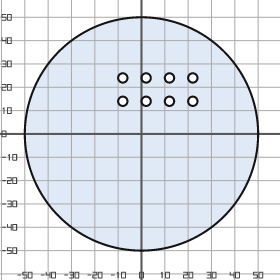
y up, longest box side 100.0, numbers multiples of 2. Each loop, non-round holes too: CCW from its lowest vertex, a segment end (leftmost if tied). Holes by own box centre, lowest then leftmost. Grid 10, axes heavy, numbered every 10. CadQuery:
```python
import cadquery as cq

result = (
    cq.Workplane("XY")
    .moveTo(0.0, 0.0)
    .circle(50.0)
    .moveTo(-8.0, 14.0)
    .circle(2.0)
    .moveTo(2.0, 14.0)
    .circle(2.0)
    .moveTo(12.0, 14.0)
    .circle(2.0)
    .moveTo(22.0, 14.0)
    .circle(2.0)
    .moveTo(-8.0, 24.0)
    .circle(2.0)
    .moveTo(2.0, 24.0)
    .circle(2.0)
    .moveTo(12.0, 24.0)
    .circle(2.0)
    .moveTo(22.0, 24.0)
    .circle(2.0)
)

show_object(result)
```